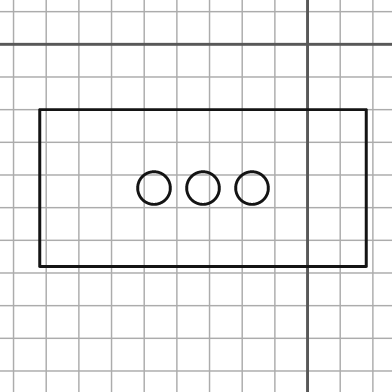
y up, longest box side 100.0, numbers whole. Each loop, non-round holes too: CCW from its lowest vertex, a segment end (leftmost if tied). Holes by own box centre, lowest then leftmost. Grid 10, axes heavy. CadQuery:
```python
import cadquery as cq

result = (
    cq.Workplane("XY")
    .moveTo(-82.0, -68.0)
    .lineTo(18.0, -68.0)
    .lineTo(18.0, -20.0)
    .lineTo(-82.0, -20.0)
    .close()
    .moveTo(-47.0, -44.0)
    .circle(5.0)
    .moveTo(-32.0, -44.0)
    .circle(5.0)
    .moveTo(-17.0, -44.0)
    .circle(5.0)
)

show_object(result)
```